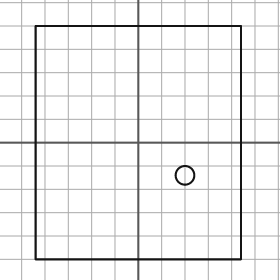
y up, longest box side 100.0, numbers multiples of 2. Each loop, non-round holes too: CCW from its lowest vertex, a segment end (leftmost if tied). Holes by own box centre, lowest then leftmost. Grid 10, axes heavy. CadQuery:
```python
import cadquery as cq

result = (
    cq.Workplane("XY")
    .moveTo(-44.0, -50.0)
    .lineTo(44.0, -50.0)
    .lineTo(44.0, 50.0)
    .lineTo(-44.0, 50.0)
    .close()
    .moveTo(20.0, -14.0)
    .circle(4.0)
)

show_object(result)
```